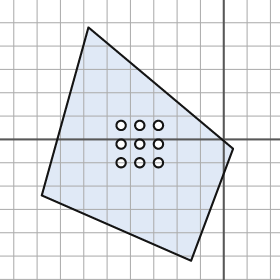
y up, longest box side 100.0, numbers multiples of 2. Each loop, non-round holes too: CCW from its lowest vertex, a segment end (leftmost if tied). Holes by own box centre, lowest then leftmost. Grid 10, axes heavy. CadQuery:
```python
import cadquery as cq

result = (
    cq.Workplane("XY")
    .moveTo(-14.0, -52.0)
    .lineTo(4.0, -4.0)
    .lineTo(-58.0, 48.0)
    .lineTo(-78.0, -24.0)
    .close()
    .moveTo(-44.0, -10.0)
    .circle(2.0)
    .moveTo(-36.0, -10.0)
    .circle(2.0)
    .moveTo(-28.0, -10.0)
    .circle(2.0)
    .moveTo(-44.0, -2.0)
    .circle(2.0)
    .moveTo(-36.0, -2.0)
    .circle(2.0)
    .moveTo(-28.0, -2.0)
    .circle(2.0)
    .moveTo(-44.0, 6.0)
    .circle(2.0)
    .moveTo(-36.0, 6.0)
    .circle(2.0)
    .moveTo(-28.0, 6.0)
    .circle(2.0)
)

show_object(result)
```